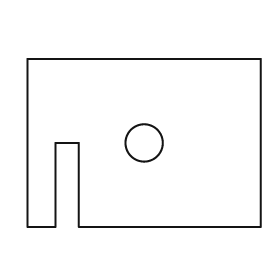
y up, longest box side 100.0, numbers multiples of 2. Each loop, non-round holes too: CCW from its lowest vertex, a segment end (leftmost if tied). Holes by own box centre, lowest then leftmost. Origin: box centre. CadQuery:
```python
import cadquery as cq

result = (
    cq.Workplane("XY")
    .moveTo(-50.0, -36.0)
    .lineTo(-38.0, -36.0)
    .lineTo(-38.0, 0.0)
    .lineTo(-28.0, 0.0)
    .lineTo(-28.0, -36.0)
    .lineTo(50.0, -36.0)
    .lineTo(50.0, 36.0)
    .lineTo(-50.0, 36.0)
    .close()
    .moveTo(0.0, 0.0)
    .circle(8.0)
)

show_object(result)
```